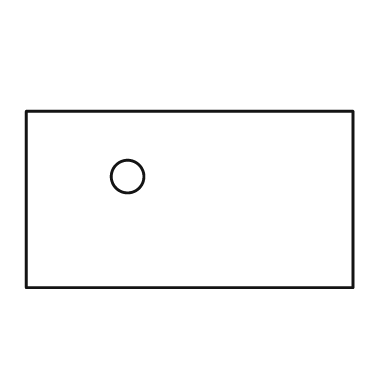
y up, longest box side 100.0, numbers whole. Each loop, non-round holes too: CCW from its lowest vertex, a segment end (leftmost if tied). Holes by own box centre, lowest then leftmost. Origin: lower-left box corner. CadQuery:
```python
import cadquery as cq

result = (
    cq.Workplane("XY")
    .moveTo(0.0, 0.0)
    .lineTo(100.0, 0.0)
    .lineTo(100.0, 54.0)
    .lineTo(0.0, 54.0)
    .close()
    .moveTo(31.0, 34.0)
    .circle(5.0)
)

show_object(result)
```